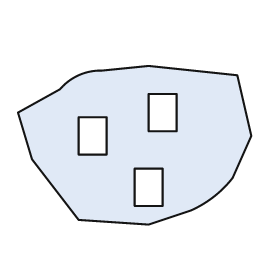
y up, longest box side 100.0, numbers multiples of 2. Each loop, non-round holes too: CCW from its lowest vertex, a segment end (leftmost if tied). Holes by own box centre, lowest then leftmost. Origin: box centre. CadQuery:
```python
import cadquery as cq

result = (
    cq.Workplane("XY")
    .moveTo(6.0, -34.0)
    .lineTo(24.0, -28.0)
    .threePointArc((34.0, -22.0), (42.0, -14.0))
    .lineTo(50.0, 4.0)
    .lineTo(44.0, 30.0)
    .lineTo(6.0, 34.0)
    .lineTo(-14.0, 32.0)
    .threePointArc((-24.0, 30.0), (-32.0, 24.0))
    .lineTo(-50.0, 14.0)
    .lineTo(-44.0, -6.0)
    .lineTo(-24.0, -32.0)
    .close()
    .moveTo(0.0, -26.0)
    .lineTo(12.0, -26.0)
    .lineTo(12.0, -10.0)
    .lineTo(0.0, -10.0)
    .close()
    .moveTo(-24.0, -4.0)
    .lineTo(-12.0, -4.0)
    .lineTo(-12.0, 12.0)
    .lineTo(-24.0, 12.0)
    .close()
    .moveTo(6.0, 6.0)
    .lineTo(18.0, 6.0)
    .lineTo(18.0, 22.0)
    .lineTo(6.0, 22.0)
    .close()
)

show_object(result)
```